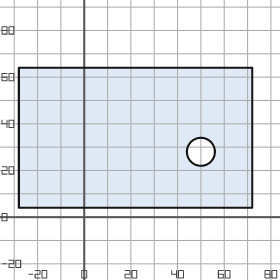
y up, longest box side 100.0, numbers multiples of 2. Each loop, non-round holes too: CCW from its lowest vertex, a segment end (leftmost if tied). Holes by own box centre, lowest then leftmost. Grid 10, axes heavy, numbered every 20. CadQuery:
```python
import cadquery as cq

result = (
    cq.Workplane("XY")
    .moveTo(-28.0, 4.0)
    .lineTo(72.0, 4.0)
    .lineTo(72.0, 64.0)
    .lineTo(-28.0, 64.0)
    .close()
    .moveTo(50.0, 28.0)
    .circle(6.0)
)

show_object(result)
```